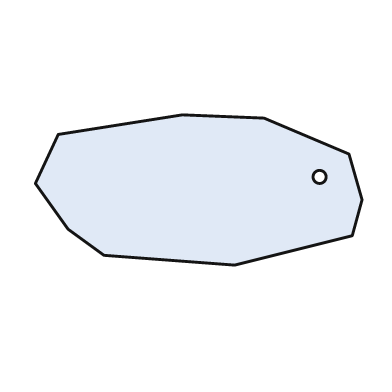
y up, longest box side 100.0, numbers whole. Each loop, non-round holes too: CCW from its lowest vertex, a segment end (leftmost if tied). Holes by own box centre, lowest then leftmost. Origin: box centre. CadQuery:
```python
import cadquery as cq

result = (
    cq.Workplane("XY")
    .moveTo(11.0, -23.0)
    .lineTo(47.0, -14.0)
    .lineTo(50.0, -3.0)
    .lineTo(46.0, 11.0)
    .lineTo(20.0, 22.0)
    .lineTo(-5.0, 23.0)
    .lineTo(-43.0, 17.0)
    .lineTo(-50.0, 2.0)
    .lineTo(-40.0, -12.0)
    .lineTo(-29.0, -20.0)
    .close()
    .moveTo(37.0, 4.0)
    .circle(2.0)
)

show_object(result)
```